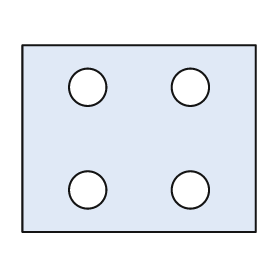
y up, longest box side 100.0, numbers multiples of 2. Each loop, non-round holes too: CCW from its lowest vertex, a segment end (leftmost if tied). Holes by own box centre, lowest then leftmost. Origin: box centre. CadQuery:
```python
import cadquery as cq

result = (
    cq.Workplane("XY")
    .moveTo(-50.0, -40.0)
    .lineTo(50.0, -40.0)
    .lineTo(50.0, 40.0)
    .lineTo(-50.0, 40.0)
    .close()
    .moveTo(-22.0, -22.0)
    .circle(8.0)
    .moveTo(22.0, -22.0)
    .circle(8.0)
    .moveTo(-22.0, 22.0)
    .circle(8.0)
    .moveTo(22.0, 22.0)
    .circle(8.0)
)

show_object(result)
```